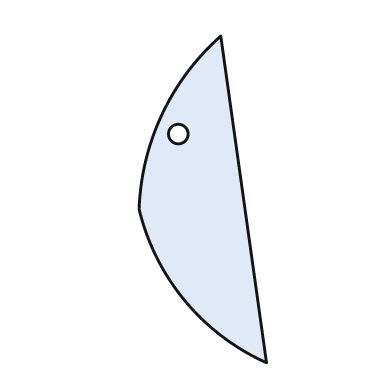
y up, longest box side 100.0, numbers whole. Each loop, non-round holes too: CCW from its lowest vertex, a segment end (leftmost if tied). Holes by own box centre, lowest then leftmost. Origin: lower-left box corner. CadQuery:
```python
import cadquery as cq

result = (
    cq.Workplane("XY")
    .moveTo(39.0, 0.0)
    .lineTo(25.0, 100.0)
    .threePointArc((7.0, 76.0), (0.0, 47.0))
    .threePointArc((14.0, 19.0), (39.0, 0.0))
    .close()
    .moveTo(12.0, 70.0)
    .circle(3.0)
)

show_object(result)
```